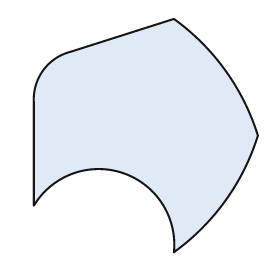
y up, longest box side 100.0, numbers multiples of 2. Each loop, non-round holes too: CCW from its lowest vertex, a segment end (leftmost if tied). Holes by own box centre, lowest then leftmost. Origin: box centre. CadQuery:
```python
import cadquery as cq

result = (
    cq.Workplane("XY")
    .moveTo(12.0, -50.0)
    .threePointArc((34.0, -28.0), (48.0, 0.0))
    .threePointArc((34.0, 28.0), (12.0, 50.0))
    .lineTo(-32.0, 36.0)
    .threePointArc((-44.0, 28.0), (-48.0, 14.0))
    .lineTo(-48.0, -30.0)
    .threePointArc((-10.0, -16.0), (12.0, -50.0))
    .close()
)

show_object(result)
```